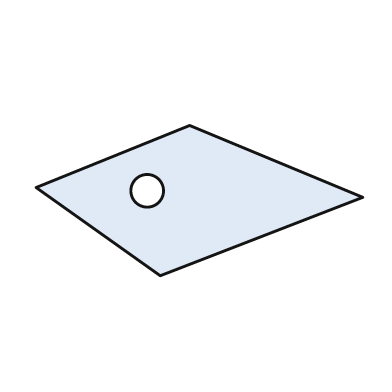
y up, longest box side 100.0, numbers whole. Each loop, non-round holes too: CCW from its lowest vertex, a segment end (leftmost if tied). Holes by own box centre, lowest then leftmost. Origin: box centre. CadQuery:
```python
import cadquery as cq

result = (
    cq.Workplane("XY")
    .moveTo(-12.0, -23.0)
    .lineTo(50.0, 1.0)
    .lineTo(-3.0, 23.0)
    .lineTo(-50.0, 4.0)
    .close()
    .moveTo(-16.0, 3.0)
    .circle(5.0)
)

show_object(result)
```